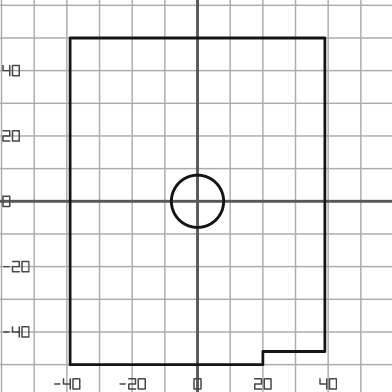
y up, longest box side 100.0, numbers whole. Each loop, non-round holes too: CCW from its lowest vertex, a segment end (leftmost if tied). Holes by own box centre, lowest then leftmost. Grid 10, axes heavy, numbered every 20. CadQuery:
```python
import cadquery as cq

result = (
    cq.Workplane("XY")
    .moveTo(-39.0, -50.0)
    .lineTo(20.0, -50.0)
    .lineTo(20.0, -46.0)
    .lineTo(39.0, -46.0)
    .lineTo(39.0, 50.0)
    .lineTo(-39.0, 50.0)
    .close()
    .moveTo(0.0, 0.0)
    .circle(8.0)
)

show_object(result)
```